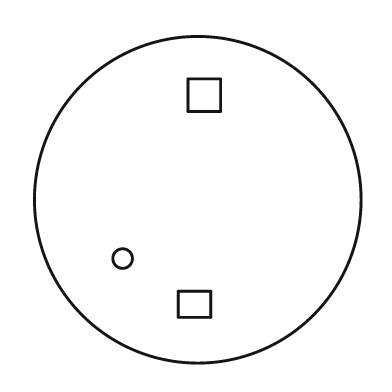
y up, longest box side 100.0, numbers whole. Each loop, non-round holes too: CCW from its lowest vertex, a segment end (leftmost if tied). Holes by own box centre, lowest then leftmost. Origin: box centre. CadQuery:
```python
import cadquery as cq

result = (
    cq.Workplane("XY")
    .moveTo(0.0, 0.0)
    .circle(50.0)
    .moveTo(-6.0, -36.0)
    .lineTo(4.0, -36.0)
    .lineTo(4.0, -28.0)
    .lineTo(-6.0, -28.0)
    .close()
    .moveTo(-23.0, -18.0)
    .circle(3.0)
    .moveTo(-3.0, 27.0)
    .lineTo(7.0, 27.0)
    .lineTo(7.0, 37.0)
    .lineTo(-3.0, 37.0)
    .close()
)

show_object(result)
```